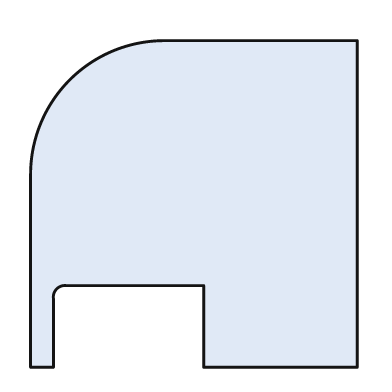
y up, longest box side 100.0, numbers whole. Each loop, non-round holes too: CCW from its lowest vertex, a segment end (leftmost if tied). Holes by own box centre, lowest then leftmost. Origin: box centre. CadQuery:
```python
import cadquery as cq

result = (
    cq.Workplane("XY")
    .moveTo(-50.0, -50.0)
    .lineTo(-43.0, -50.0)
    .lineTo(-43.0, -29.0)
    .threePointArc((-42.0, -26.0), (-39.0, -25.0))
    .lineTo(3.0, -25.0)
    .lineTo(3.0, -50.0)
    .lineTo(50.0, -50.0)
    .lineTo(50.0, 50.0)
    .lineTo(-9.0, 50.0)
    .threePointArc((-38.0, 38.0), (-50.0, 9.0))
    .close()
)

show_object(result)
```